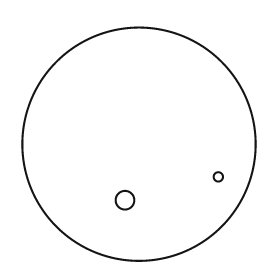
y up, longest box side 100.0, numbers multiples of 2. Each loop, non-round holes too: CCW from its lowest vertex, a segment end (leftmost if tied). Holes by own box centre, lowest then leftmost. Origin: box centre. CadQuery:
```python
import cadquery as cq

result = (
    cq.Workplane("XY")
    .moveTo(0.0, 0.0)
    .circle(50.0)
    .moveTo(-6.0, -24.0)
    .circle(4.0)
    .moveTo(34.0, -14.0)
    .circle(2.0)
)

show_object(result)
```